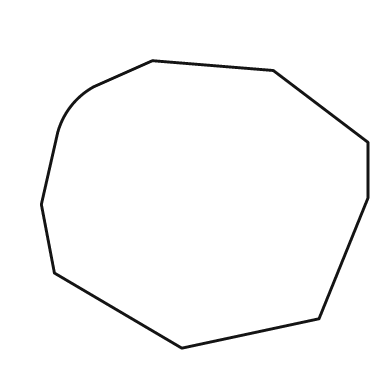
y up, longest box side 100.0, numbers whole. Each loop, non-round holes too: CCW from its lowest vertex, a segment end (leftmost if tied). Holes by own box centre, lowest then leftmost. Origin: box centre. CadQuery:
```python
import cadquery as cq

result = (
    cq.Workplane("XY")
    .moveTo(-7.0, -44.0)
    .lineTo(35.0, -35.0)
    .lineTo(50.0, 2.0)
    .lineTo(50.0, 19.0)
    .lineTo(21.0, 41.0)
    .lineTo(-16.0, 44.0)
    .lineTo(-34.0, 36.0)
    .threePointArc((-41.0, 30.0), (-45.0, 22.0))
    .lineTo(-50.0, 0.0)
    .lineTo(-46.0, -21.0)
    .close()
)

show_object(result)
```